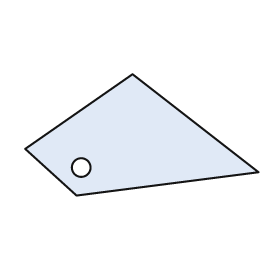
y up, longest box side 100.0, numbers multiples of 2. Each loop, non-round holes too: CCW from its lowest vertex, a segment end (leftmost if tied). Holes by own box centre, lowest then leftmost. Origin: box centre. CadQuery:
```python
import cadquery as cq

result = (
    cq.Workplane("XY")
    .moveTo(-28.0, -26.0)
    .lineTo(50.0, -16.0)
    .lineTo(-4.0, 26.0)
    .lineTo(-50.0, -6.0)
    .close()
    .moveTo(-26.0, -14.0)
    .circle(4.0)
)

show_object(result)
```